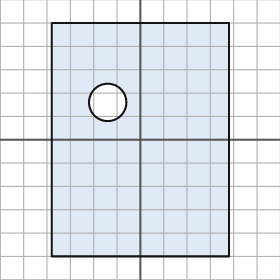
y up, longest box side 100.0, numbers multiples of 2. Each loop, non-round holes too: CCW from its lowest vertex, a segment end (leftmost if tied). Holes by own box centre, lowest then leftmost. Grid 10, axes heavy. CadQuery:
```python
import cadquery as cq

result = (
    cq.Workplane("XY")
    .moveTo(-38.0, -50.0)
    .lineTo(38.0, -50.0)
    .lineTo(38.0, 50.0)
    .lineTo(-38.0, 50.0)
    .close()
    .moveTo(-14.0, 16.0)
    .circle(8.0)
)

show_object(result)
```